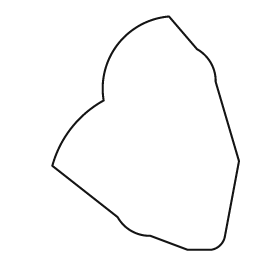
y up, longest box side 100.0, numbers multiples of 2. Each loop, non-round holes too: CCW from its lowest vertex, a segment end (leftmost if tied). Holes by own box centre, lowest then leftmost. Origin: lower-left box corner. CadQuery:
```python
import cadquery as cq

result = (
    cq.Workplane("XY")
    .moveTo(58.0, 0.0)
    .lineTo(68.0, 0.0)
    .threePointArc((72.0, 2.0), (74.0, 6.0))
    .lineTo(80.0, 38.0)
    .lineTo(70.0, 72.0)
    .threePointArc((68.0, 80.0), (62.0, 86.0))
    .lineTo(50.0, 100.0)
    .threePointArc((28.0, 88.0), (22.0, 64.0))
    .threePointArc((8.0, 52.0), (0.0, 36.0))
    .lineTo(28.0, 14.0)
    .threePointArc((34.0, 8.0), (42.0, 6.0))
    .close()
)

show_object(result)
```